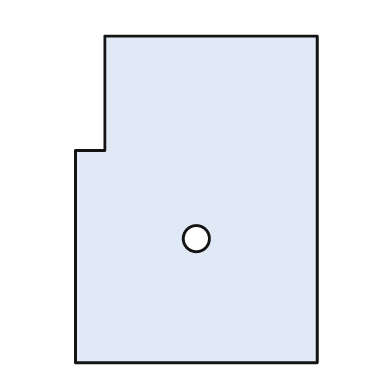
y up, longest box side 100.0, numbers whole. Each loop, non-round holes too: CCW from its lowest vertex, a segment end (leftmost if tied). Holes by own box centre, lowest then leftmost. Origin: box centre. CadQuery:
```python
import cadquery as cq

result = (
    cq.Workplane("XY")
    .moveTo(-37.0, -50.0)
    .lineTo(37.0, -50.0)
    .lineTo(37.0, 50.0)
    .lineTo(-28.0, 50.0)
    .lineTo(-28.0, 15.0)
    .lineTo(-37.0, 15.0)
    .close()
    .moveTo(0.0, -12.0)
    .circle(4.0)
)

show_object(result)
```